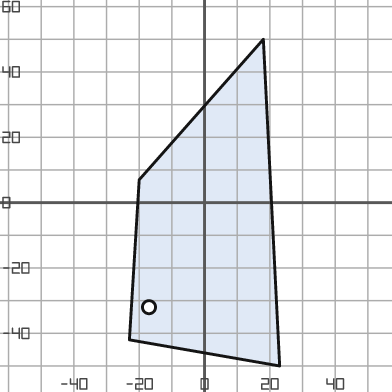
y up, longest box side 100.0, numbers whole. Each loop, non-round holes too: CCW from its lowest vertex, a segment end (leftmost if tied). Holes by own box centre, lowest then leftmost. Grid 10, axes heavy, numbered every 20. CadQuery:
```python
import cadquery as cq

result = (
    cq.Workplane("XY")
    .moveTo(23.0, -50.0)
    .lineTo(18.0, 50.0)
    .lineTo(-20.0, 7.0)
    .lineTo(-23.0, -42.0)
    .close()
    .moveTo(-17.0, -32.0)
    .circle(2.0)
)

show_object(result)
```